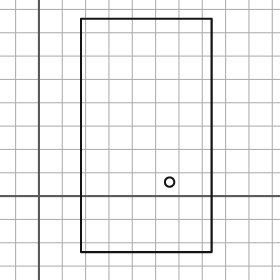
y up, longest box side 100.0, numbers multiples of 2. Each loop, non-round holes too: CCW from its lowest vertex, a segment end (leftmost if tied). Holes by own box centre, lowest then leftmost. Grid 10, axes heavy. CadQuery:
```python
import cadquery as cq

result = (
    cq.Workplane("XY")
    .moveTo(18.0, -24.0)
    .lineTo(74.0, -24.0)
    .lineTo(74.0, 76.0)
    .lineTo(18.0, 76.0)
    .close()
    .moveTo(56.0, 6.0)
    .circle(2.0)
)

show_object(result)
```